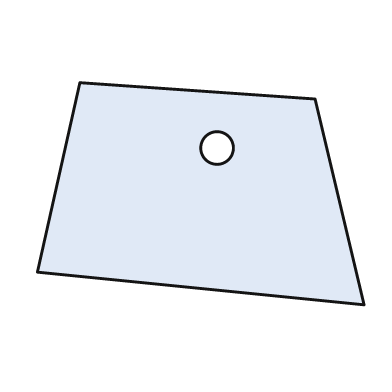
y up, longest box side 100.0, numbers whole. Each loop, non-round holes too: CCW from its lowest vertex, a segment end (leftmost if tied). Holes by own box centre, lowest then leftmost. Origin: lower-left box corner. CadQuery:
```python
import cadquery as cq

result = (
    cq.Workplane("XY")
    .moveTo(100.0, 0.0)
    .lineTo(85.0, 63.0)
    .lineTo(13.0, 68.0)
    .lineTo(0.0, 10.0)
    .close()
    .moveTo(55.0, 48.0)
    .circle(5.0)
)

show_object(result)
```